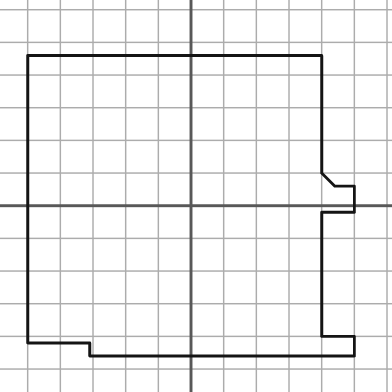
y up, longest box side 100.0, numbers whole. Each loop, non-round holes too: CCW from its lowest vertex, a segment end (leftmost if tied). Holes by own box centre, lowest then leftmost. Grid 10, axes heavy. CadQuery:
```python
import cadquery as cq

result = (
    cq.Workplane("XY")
    .moveTo(-31.0, -46.0)
    .lineTo(50.0, -46.0)
    .lineTo(50.0, -40.0)
    .lineTo(40.0, -40.0)
    .lineTo(40.0, -2.0)
    .lineTo(50.0, -2.0)
    .lineTo(50.0, 6.0)
    .lineTo(44.0, 6.0)
    .lineTo(40.0, 10.0)
    .lineTo(40.0, 46.0)
    .lineTo(-50.0, 46.0)
    .lineTo(-50.0, -42.0)
    .lineTo(-31.0, -42.0)
    .close()
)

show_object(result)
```